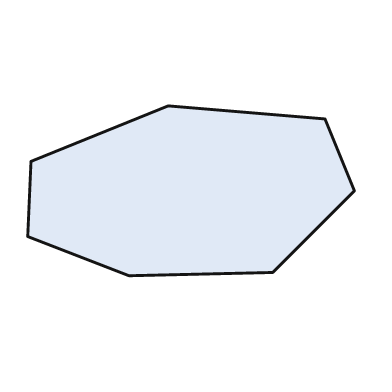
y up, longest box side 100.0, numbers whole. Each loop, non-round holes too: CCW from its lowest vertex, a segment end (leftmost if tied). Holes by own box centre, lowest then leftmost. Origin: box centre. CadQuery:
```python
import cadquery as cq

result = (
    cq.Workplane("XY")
    .moveTo(-19.0, -26.0)
    .lineTo(25.0, -25.0)
    .lineTo(50.0, 0.0)
    .lineTo(41.0, 22.0)
    .lineTo(-7.0, 26.0)
    .lineTo(-49.0, 9.0)
    .lineTo(-50.0, -14.0)
    .close()
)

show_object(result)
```